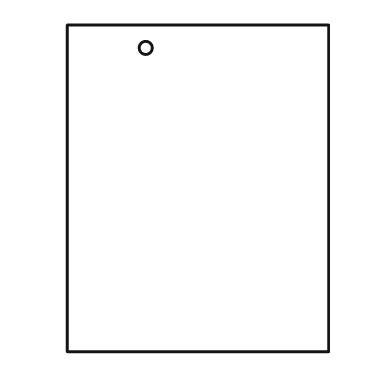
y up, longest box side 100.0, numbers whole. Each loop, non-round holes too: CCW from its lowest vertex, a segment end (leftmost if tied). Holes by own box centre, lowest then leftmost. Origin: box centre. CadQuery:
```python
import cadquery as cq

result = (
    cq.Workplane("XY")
    .moveTo(-40.0, -50.0)
    .lineTo(40.0, -50.0)
    .lineTo(40.0, 50.0)
    .lineTo(-40.0, 50.0)
    .close()
    .moveTo(-16.0, 43.0)
    .circle(2.0)
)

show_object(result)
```